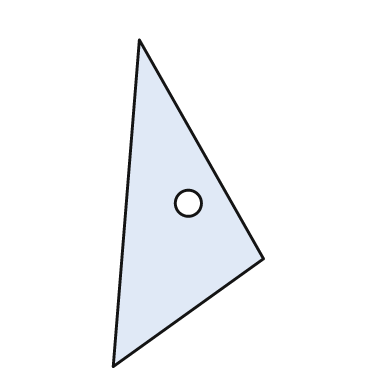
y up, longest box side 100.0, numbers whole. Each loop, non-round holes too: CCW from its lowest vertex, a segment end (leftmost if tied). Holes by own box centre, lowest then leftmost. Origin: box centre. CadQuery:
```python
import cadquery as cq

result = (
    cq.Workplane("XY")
    .moveTo(-23.0, -50.0)
    .lineTo(23.0, -17.0)
    .lineTo(-15.0, 50.0)
    .close()
    .moveTo(0.0, 0.0)
    .circle(4.0)
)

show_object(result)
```